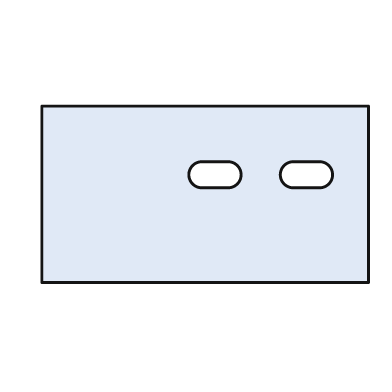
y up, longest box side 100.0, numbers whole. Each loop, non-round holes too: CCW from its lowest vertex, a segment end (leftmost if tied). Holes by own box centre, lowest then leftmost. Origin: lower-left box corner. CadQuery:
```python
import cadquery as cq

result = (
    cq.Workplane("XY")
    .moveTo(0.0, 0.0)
    .lineTo(100.0, 0.0)
    .lineTo(100.0, 54.0)
    .lineTo(0.0, 54.0)
    .close()
    .moveTo(49.0, 29.0)
    .lineTo(57.0, 29.0)
    .threePointArc((61.0, 33.0), (57.0, 37.0))
    .lineTo(49.0, 37.0)
    .threePointArc((45.0, 33.0), (49.0, 29.0))
    .close()
    .moveTo(77.0, 29.0)
    .lineTo(85.0, 29.0)
    .threePointArc((89.0, 33.0), (85.0, 37.0))
    .lineTo(77.0, 37.0)
    .threePointArc((73.0, 33.0), (77.0, 29.0))
    .close()
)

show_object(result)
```